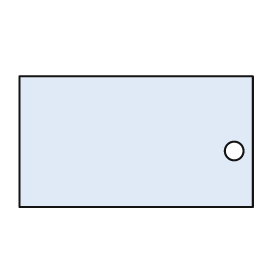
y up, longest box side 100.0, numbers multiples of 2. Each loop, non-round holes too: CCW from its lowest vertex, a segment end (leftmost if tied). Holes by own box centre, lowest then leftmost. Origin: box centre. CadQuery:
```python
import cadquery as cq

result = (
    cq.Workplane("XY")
    .moveTo(-50.0, -28.0)
    .lineTo(50.0, -28.0)
    .lineTo(50.0, 28.0)
    .lineTo(-50.0, 28.0)
    .close()
    .moveTo(42.0, -4.0)
    .circle(4.0)
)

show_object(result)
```